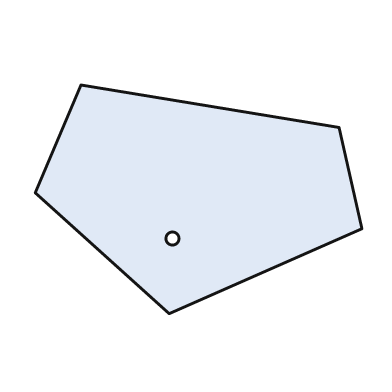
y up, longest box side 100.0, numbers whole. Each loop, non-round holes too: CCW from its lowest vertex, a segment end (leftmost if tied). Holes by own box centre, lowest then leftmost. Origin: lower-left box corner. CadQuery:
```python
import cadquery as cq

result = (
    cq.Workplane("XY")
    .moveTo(41.0, 0.0)
    .lineTo(100.0, 26.0)
    .lineTo(93.0, 57.0)
    .lineTo(14.0, 70.0)
    .lineTo(0.0, 37.0)
    .close()
    .moveTo(42.0, 23.0)
    .circle(2.0)
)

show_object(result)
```